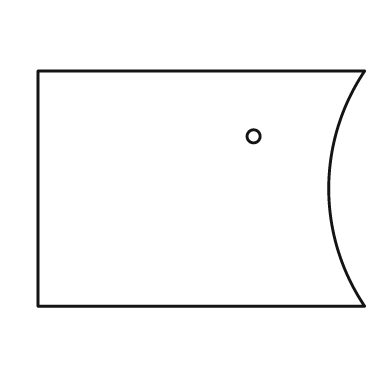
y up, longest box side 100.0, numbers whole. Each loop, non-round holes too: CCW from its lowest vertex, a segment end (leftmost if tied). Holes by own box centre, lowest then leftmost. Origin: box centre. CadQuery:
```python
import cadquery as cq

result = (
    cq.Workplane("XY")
    .moveTo(-50.0, -36.0)
    .lineTo(50.0, -36.0)
    .threePointArc((39.0, 0.0), (50.0, 36.0))
    .lineTo(-50.0, 36.0)
    .close()
    .moveTo(16.0, 16.0)
    .circle(2.0)
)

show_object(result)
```